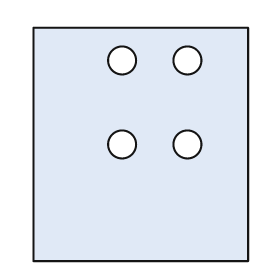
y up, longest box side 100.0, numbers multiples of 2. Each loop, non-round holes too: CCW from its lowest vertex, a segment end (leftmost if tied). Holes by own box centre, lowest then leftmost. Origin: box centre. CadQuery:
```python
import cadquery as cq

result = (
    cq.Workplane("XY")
    .moveTo(-46.0, -50.0)
    .lineTo(46.0, -50.0)
    .lineTo(46.0, 50.0)
    .lineTo(-46.0, 50.0)
    .close()
    .moveTo(-8.0, 0.0)
    .circle(6.0)
    .moveTo(20.0, 0.0)
    .circle(6.0)
    .moveTo(-8.0, 36.0)
    .circle(6.0)
    .moveTo(20.0, 36.0)
    .circle(6.0)
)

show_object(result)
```